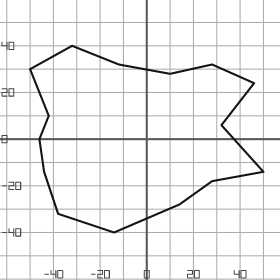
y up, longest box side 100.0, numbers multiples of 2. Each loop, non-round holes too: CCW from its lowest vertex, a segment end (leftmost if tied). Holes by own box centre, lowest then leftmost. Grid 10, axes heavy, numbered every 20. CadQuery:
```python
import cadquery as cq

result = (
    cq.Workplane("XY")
    .moveTo(-14.0, -40.0)
    .lineTo(14.0, -28.0)
    .lineTo(28.0, -18.0)
    .lineTo(50.0, -14.0)
    .lineTo(32.0, 6.0)
    .lineTo(46.0, 24.0)
    .lineTo(28.0, 32.0)
    .lineTo(10.0, 28.0)
    .lineTo(-12.0, 32.0)
    .lineTo(-32.0, 40.0)
    .lineTo(-50.0, 30.0)
    .lineTo(-42.0, 10.0)
    .lineTo(-46.0, 0.0)
    .lineTo(-44.0, -14.0)
    .lineTo(-38.0, -32.0)
    .close()
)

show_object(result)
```